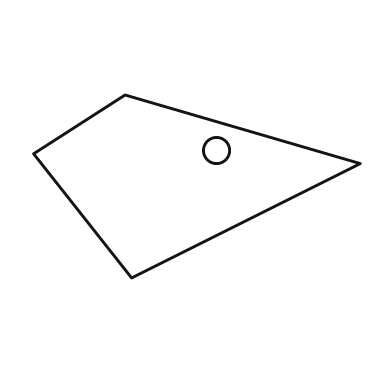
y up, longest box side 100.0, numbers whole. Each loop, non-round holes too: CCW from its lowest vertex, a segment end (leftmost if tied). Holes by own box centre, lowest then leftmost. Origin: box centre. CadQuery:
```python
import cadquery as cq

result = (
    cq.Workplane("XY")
    .moveTo(-20.0, -28.0)
    .lineTo(50.0, 7.0)
    .lineTo(-22.0, 28.0)
    .lineTo(-50.0, 10.0)
    .close()
    .moveTo(6.0, 11.0)
    .circle(4.0)
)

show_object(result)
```